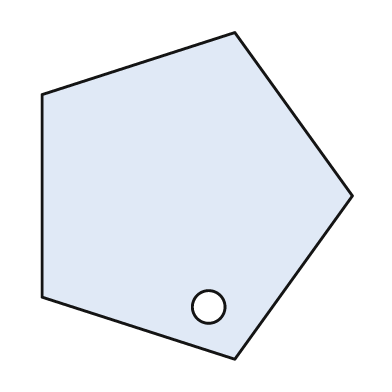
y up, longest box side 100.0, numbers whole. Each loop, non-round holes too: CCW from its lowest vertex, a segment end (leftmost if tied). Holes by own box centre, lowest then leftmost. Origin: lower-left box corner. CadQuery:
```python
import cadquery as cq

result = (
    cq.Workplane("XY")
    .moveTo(59.0, 0.0)
    .lineTo(95.0, 50.0)
    .lineTo(59.0, 100.0)
    .lineTo(0.0, 81.0)
    .lineTo(0.0, 19.0)
    .close()
    .moveTo(51.0, 16.0)
    .circle(5.0)
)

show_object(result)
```